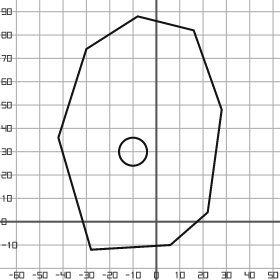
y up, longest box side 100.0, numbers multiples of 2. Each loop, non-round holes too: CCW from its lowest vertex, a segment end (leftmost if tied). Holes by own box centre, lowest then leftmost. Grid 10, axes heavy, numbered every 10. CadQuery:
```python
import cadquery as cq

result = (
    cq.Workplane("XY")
    .moveTo(-28.0, -12.0)
    .lineTo(6.0, -10.0)
    .lineTo(22.0, 4.0)
    .lineTo(28.0, 48.0)
    .lineTo(16.0, 82.0)
    .lineTo(-8.0, 88.0)
    .lineTo(-30.0, 74.0)
    .lineTo(-42.0, 36.0)
    .close()
    .moveTo(-10.0, 30.0)
    .circle(6.0)
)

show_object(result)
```